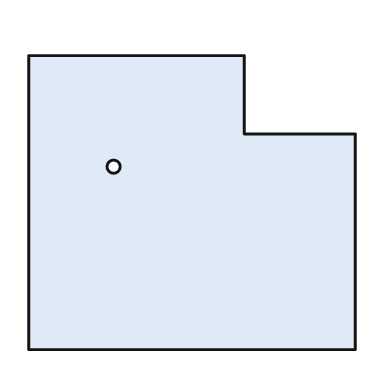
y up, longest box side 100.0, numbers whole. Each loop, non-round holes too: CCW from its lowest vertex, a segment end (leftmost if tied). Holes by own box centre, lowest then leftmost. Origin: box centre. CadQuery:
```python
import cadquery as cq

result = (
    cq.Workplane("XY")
    .moveTo(-50.0, -45.0)
    .lineTo(50.0, -45.0)
    .lineTo(50.0, 21.0)
    .lineTo(16.0, 21.0)
    .lineTo(16.0, 45.0)
    .lineTo(-50.0, 45.0)
    .close()
    .moveTo(-24.0, 11.0)
    .circle(2.0)
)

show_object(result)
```